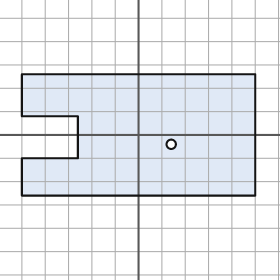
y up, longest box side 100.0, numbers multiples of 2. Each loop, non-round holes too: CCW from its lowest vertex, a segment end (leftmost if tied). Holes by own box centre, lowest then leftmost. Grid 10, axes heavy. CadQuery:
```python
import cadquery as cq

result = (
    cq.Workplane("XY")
    .moveTo(-50.0, -26.0)
    .lineTo(50.0, -26.0)
    .lineTo(50.0, 26.0)
    .lineTo(-50.0, 26.0)
    .lineTo(-50.0, 8.0)
    .lineTo(-26.0, 8.0)
    .lineTo(-26.0, -10.0)
    .lineTo(-50.0, -10.0)
    .close()
    .moveTo(14.0, -4.0)
    .circle(2.0)
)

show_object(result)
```